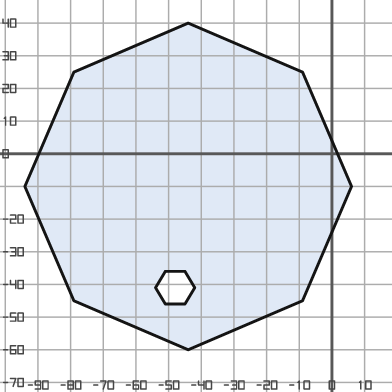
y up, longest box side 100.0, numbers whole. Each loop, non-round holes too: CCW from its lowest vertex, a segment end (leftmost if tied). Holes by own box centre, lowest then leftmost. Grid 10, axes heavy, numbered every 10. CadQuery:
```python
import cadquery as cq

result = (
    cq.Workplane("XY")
    .moveTo(-44.0, -60.0)
    .lineTo(-9.0, -45.0)
    .lineTo(6.0, -10.0)
    .lineTo(-9.0, 25.0)
    .lineTo(-44.0, 40.0)
    .lineTo(-79.0, 25.0)
    .lineTo(-94.0, -10.0)
    .lineTo(-79.0, -45.0)
    .close()
    .moveTo(-51.0, -46.0)
    .lineTo(-45.0, -46.0)
    .lineTo(-42.0, -41.0)
    .lineTo(-45.0, -36.0)
    .lineTo(-51.0, -36.0)
    .lineTo(-54.0, -41.0)
    .close()
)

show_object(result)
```